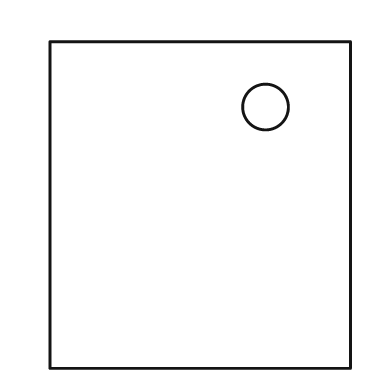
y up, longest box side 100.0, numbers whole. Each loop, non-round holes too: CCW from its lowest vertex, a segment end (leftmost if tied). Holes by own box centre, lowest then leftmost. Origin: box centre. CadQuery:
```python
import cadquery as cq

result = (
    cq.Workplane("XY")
    .moveTo(-46.0, -50.0)
    .lineTo(46.0, -50.0)
    .lineTo(46.0, 50.0)
    .lineTo(-46.0, 50.0)
    .close()
    .moveTo(20.0, 30.0)
    .circle(7.0)
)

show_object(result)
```